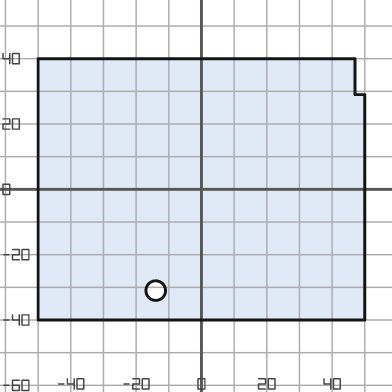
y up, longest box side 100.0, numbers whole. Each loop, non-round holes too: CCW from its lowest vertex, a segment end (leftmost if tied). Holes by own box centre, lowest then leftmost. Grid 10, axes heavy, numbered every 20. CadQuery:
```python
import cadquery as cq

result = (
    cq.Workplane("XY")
    .moveTo(-50.0, -40.0)
    .lineTo(50.0, -40.0)
    .lineTo(50.0, 29.0)
    .lineTo(47.0, 29.0)
    .lineTo(47.0, 40.0)
    .lineTo(-50.0, 40.0)
    .close()
    .moveTo(-14.0, -31.0)
    .circle(3.0)
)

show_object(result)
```